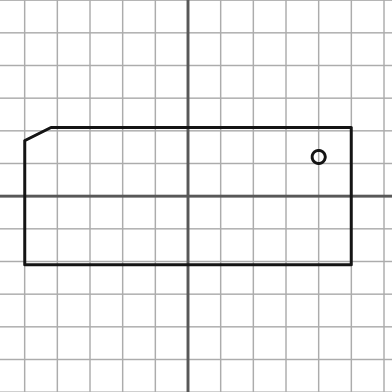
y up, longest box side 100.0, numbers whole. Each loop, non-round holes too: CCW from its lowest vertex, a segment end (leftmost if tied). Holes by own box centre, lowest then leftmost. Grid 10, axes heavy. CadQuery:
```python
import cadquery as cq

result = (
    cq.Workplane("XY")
    .moveTo(-50.0, -21.0)
    .lineTo(50.0, -21.0)
    .lineTo(50.0, 21.0)
    .lineTo(-42.0, 21.0)
    .lineTo(-50.0, 17.0)
    .close()
    .moveTo(40.0, 12.0)
    .circle(2.0)
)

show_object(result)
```